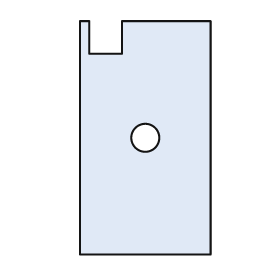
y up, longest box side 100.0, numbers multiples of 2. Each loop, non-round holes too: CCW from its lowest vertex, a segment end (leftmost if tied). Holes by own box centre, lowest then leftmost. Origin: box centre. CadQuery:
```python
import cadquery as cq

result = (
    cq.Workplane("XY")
    .moveTo(-28.0, -50.0)
    .lineTo(28.0, -50.0)
    .lineTo(28.0, 50.0)
    .lineTo(-10.0, 50.0)
    .lineTo(-10.0, 36.0)
    .lineTo(-24.0, 36.0)
    .lineTo(-24.0, 50.0)
    .lineTo(-28.0, 50.0)
    .close()
    .moveTo(0.0, 0.0)
    .circle(6.0)
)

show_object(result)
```